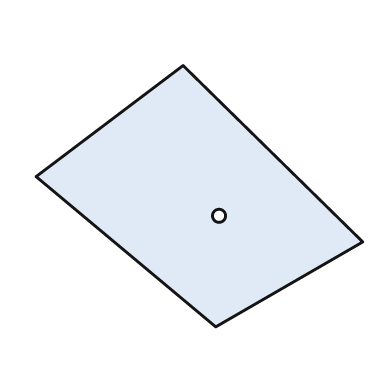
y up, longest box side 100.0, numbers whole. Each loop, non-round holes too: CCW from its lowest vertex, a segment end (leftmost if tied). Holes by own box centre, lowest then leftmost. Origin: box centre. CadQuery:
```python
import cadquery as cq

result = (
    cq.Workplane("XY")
    .moveTo(5.0, -40.0)
    .lineTo(50.0, -14.0)
    .lineTo(-5.0, 40.0)
    .lineTo(-50.0, 6.0)
    .close()
    .moveTo(6.0, -6.0)
    .circle(2.0)
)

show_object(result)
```